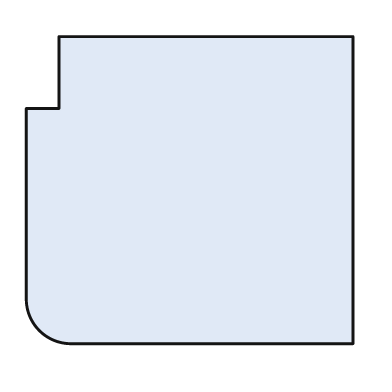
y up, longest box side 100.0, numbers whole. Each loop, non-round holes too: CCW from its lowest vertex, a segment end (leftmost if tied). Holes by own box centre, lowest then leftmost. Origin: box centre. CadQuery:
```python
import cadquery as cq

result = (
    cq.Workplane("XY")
    .moveTo(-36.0, -47.0)
    .lineTo(50.0, -47.0)
    .lineTo(50.0, 47.0)
    .lineTo(-40.0, 47.0)
    .lineTo(-40.0, 25.0)
    .lineTo(-50.0, 25.0)
    .lineTo(-50.0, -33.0)
    .threePointArc((-46.0, -43.0), (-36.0, -47.0))
    .close()
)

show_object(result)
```